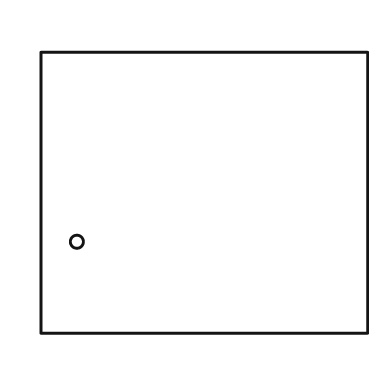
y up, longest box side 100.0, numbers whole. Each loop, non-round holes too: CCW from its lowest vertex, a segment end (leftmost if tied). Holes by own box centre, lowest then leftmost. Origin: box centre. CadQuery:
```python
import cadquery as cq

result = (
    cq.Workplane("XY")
    .moveTo(-50.0, -43.0)
    .lineTo(50.0, -43.0)
    .lineTo(50.0, 43.0)
    .lineTo(-50.0, 43.0)
    .close()
    .moveTo(-39.0, -15.0)
    .circle(2.0)
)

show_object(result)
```